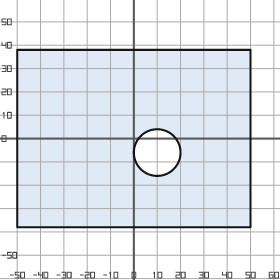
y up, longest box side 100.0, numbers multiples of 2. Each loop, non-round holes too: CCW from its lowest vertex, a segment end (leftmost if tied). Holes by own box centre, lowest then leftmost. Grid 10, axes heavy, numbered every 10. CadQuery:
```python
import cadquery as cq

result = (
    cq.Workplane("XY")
    .moveTo(-50.0, -38.0)
    .lineTo(50.0, -38.0)
    .lineTo(50.0, 38.0)
    .lineTo(-50.0, 38.0)
    .close()
    .moveTo(10.0, -6.0)
    .circle(10.0)
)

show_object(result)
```